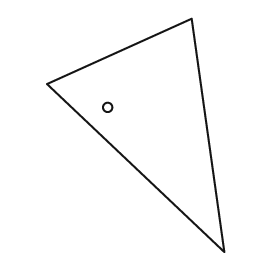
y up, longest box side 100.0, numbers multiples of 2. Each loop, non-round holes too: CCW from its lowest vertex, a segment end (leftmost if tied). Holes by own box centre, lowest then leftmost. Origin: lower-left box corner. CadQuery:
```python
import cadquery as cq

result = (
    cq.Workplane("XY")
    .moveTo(76.0, 0.0)
    .lineTo(62.0, 100.0)
    .lineTo(0.0, 72.0)
    .close()
    .moveTo(26.0, 62.0)
    .circle(2.0)
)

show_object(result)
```